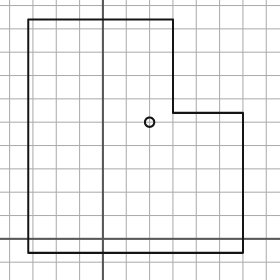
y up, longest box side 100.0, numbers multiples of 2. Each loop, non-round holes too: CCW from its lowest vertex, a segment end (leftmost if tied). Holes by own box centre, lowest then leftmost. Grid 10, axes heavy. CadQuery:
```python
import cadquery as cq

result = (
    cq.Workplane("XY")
    .moveTo(-32.0, -6.0)
    .lineTo(60.0, -6.0)
    .lineTo(60.0, 54.0)
    .lineTo(30.0, 54.0)
    .lineTo(30.0, 94.0)
    .lineTo(-32.0, 94.0)
    .close()
    .moveTo(20.0, 50.0)
    .circle(2.0)
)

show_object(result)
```